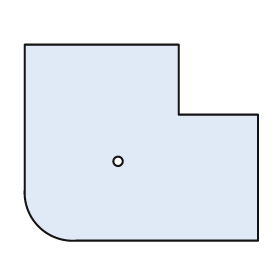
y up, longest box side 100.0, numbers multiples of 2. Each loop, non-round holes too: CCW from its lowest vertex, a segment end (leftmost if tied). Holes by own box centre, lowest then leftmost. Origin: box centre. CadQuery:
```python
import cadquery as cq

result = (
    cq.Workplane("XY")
    .moveTo(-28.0, -42.0)
    .lineTo(50.0, -42.0)
    .lineTo(50.0, 12.0)
    .lineTo(16.0, 12.0)
    .lineTo(16.0, 42.0)
    .lineTo(-50.0, 42.0)
    .lineTo(-50.0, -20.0)
    .threePointArc((-44.0, -36.0), (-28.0, -42.0))
    .close()
    .moveTo(-10.0, -8.0)
    .circle(2.0)
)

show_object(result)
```